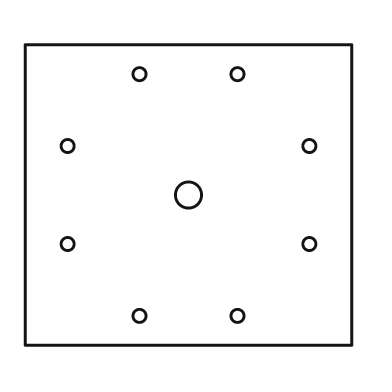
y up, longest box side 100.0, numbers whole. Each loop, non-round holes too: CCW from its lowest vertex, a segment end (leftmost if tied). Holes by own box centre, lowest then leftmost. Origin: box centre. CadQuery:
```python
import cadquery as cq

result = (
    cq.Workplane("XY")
    .moveTo(-50.0, -46.0)
    .lineTo(50.0, -46.0)
    .lineTo(50.0, 46.0)
    .lineTo(-50.0, 46.0)
    .close()
    .moveTo(-15.0, -37.0)
    .circle(2.0)
    .moveTo(15.0, -37.0)
    .circle(2.0)
    .moveTo(-37.0, -15.0)
    .circle(2.0)
    .moveTo(37.0, -15.0)
    .circle(2.0)
    .moveTo(0.0, 0.0)
    .circle(4.0)
    .moveTo(-37.0, 15.0)
    .circle(2.0)
    .moveTo(37.0, 15.0)
    .circle(2.0)
    .moveTo(-15.0, 37.0)
    .circle(2.0)
    .moveTo(15.0, 37.0)
    .circle(2.0)
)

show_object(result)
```